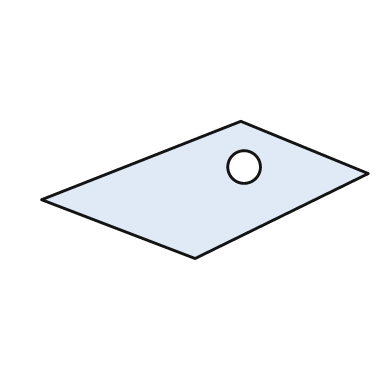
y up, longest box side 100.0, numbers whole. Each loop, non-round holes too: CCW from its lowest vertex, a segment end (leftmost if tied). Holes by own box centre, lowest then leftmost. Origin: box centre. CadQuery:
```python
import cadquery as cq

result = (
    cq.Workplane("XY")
    .moveTo(-3.0, -21.0)
    .lineTo(50.0, 5.0)
    .lineTo(11.0, 21.0)
    .lineTo(-50.0, -3.0)
    .close()
    .moveTo(12.0, 7.0)
    .circle(5.0)
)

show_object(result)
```